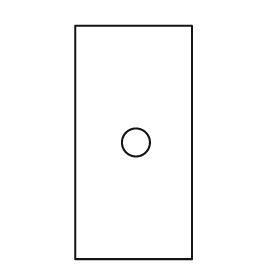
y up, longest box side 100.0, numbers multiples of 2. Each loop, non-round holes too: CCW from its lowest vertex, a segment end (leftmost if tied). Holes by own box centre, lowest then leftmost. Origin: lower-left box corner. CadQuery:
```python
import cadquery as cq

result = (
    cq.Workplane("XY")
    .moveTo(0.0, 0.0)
    .lineTo(50.0, 0.0)
    .lineTo(50.0, 100.0)
    .lineTo(0.0, 100.0)
    .close()
    .moveTo(26.0, 50.0)
    .circle(6.0)
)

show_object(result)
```